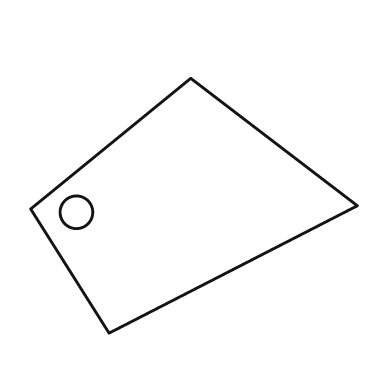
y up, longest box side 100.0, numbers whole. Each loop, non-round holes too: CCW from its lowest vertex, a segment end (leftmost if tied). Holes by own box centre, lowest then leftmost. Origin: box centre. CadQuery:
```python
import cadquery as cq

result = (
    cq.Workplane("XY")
    .moveTo(-26.0, -39.0)
    .lineTo(50.0, 0.0)
    .lineTo(-1.0, 39.0)
    .lineTo(-50.0, -1.0)
    .close()
    .moveTo(-36.0, -2.0)
    .circle(5.0)
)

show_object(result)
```